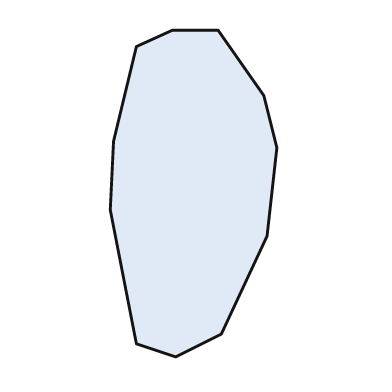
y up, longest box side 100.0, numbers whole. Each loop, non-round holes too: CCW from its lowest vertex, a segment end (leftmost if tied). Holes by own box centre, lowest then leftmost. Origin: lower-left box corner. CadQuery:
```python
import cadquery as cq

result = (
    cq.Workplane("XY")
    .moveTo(20.0, 0.0)
    .lineTo(34.0, 7.0)
    .lineTo(48.0, 37.0)
    .lineTo(51.0, 64.0)
    .lineTo(47.0, 80.0)
    .lineTo(33.0, 100.0)
    .lineTo(19.0, 100.0)
    .lineTo(8.0, 95.0)
    .lineTo(1.0, 66.0)
    .lineTo(0.0, 45.0)
    .lineTo(8.0, 4.0)
    .close()
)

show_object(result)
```